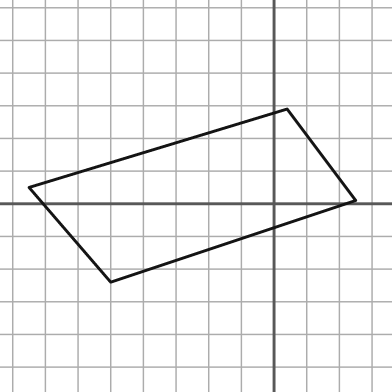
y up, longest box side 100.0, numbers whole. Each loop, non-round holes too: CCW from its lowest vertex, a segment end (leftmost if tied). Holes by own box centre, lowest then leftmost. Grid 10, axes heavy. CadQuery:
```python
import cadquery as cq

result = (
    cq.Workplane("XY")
    .moveTo(-50.0, -24.0)
    .lineTo(25.0, 1.0)
    .lineTo(4.0, 29.0)
    .lineTo(-75.0, 5.0)
    .close()
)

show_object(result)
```